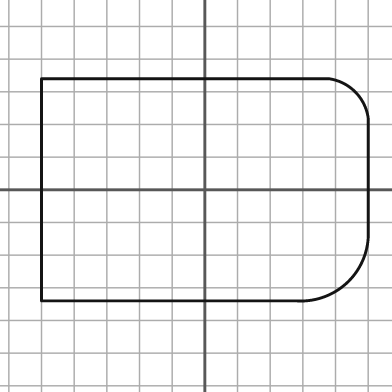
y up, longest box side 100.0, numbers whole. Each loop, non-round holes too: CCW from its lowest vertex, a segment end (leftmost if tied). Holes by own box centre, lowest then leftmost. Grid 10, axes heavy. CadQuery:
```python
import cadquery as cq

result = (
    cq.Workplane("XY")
    .moveTo(-50.0, -34.0)
    .lineTo(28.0, -34.0)
    .threePointArc((44.0, -28.0), (50.0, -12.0))
    .lineTo(50.0, 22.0)
    .threePointArc((46.0, 30.0), (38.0, 34.0))
    .lineTo(-50.0, 34.0)
    .close()
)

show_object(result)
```